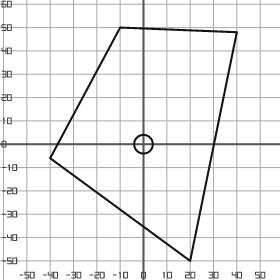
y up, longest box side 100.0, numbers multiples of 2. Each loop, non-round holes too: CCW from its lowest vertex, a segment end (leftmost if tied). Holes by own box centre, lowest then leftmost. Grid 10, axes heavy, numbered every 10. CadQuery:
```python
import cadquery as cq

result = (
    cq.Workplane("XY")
    .moveTo(20.0, -50.0)
    .lineTo(40.0, 48.0)
    .lineTo(-10.0, 50.0)
    .lineTo(-40.0, -6.0)
    .close()
    .moveTo(0.0, 0.0)
    .circle(4.0)
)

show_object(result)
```